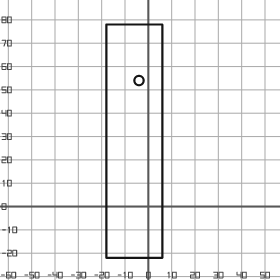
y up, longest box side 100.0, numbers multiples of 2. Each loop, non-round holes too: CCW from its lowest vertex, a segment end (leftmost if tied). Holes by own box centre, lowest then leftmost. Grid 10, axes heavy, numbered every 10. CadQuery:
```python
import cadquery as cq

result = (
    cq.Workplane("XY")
    .moveTo(-18.0, -22.0)
    .lineTo(6.0, -22.0)
    .lineTo(6.0, 78.0)
    .lineTo(-18.0, 78.0)
    .close()
    .moveTo(-4.0, 54.0)
    .circle(2.0)
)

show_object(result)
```